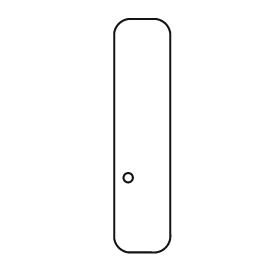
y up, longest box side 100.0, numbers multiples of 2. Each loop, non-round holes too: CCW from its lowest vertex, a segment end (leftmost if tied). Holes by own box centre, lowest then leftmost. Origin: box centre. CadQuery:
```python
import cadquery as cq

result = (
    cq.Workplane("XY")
    .moveTo(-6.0, -50.0)
    .lineTo(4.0, -50.0)
    .threePointArc((10.0, -48.0), (12.0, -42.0))
    .lineTo(12.0, 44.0)
    .threePointArc((10.0, 48.0), (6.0, 50.0))
    .lineTo(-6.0, 50.0)
    .threePointArc((-10.0, 48.0), (-12.0, 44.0))
    .lineTo(-12.0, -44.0)
    .threePointArc((-10.0, -48.0), (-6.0, -50.0))
    .close()
    .moveTo(-6.0, -18.0)
    .circle(2.0)
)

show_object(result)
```